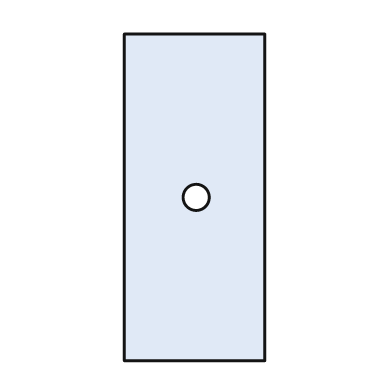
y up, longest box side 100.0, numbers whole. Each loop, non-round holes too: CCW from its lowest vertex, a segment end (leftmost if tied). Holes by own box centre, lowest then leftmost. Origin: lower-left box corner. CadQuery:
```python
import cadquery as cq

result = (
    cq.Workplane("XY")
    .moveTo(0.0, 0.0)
    .lineTo(43.0, 0.0)
    .lineTo(43.0, 100.0)
    .lineTo(0.0, 100.0)
    .close()
    .moveTo(22.0, 50.0)
    .circle(4.0)
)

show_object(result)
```